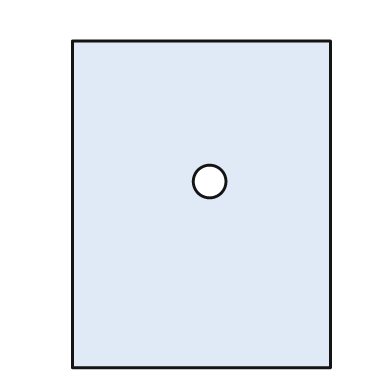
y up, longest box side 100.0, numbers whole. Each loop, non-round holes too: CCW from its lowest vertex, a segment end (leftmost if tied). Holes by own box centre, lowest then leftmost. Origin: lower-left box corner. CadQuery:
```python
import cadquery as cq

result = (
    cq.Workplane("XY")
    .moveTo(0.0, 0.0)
    .lineTo(79.0, 0.0)
    .lineTo(79.0, 100.0)
    .lineTo(0.0, 100.0)
    .close()
    .moveTo(42.0, 57.0)
    .circle(5.0)
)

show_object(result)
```